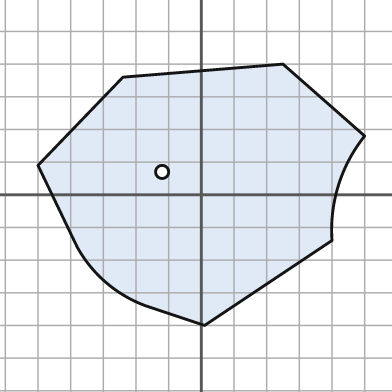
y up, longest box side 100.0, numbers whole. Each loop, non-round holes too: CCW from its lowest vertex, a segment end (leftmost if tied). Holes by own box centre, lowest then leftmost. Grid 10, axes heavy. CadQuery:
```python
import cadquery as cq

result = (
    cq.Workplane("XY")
    .moveTo(1.0, -40.0)
    .lineTo(40.0, -14.0)
    .threePointArc((42.0, 3.0), (50.0, 18.0))
    .lineTo(25.0, 40.0)
    .lineTo(-24.0, 36.0)
    .lineTo(-50.0, 9.0)
    .lineTo(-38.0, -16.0)
    .threePointArc((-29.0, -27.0), (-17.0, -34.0))
    .close()
    .moveTo(-12.0, 7.0)
    .circle(2.0)
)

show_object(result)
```